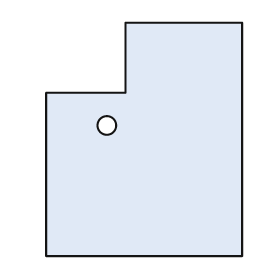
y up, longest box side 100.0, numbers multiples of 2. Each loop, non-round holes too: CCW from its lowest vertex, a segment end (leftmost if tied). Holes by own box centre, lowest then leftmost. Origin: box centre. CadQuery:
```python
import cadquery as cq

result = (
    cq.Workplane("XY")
    .moveTo(-42.0, -50.0)
    .lineTo(42.0, -50.0)
    .lineTo(42.0, 50.0)
    .lineTo(-8.0, 50.0)
    .lineTo(-8.0, 20.0)
    .lineTo(-42.0, 20.0)
    .close()
    .moveTo(-16.0, 6.0)
    .circle(4.0)
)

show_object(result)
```